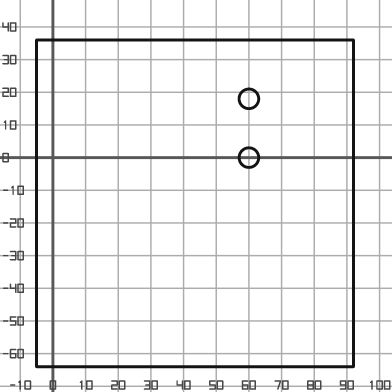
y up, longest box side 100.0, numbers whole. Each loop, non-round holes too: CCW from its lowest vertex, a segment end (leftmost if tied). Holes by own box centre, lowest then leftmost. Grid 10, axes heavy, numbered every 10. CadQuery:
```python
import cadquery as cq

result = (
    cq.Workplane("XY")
    .moveTo(-5.0, -64.0)
    .lineTo(92.0, -64.0)
    .lineTo(92.0, 36.0)
    .lineTo(-5.0, 36.0)
    .close()
    .moveTo(60.0, 0.0)
    .circle(3.0)
    .moveTo(60.0, 18.0)
    .circle(3.0)
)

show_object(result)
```